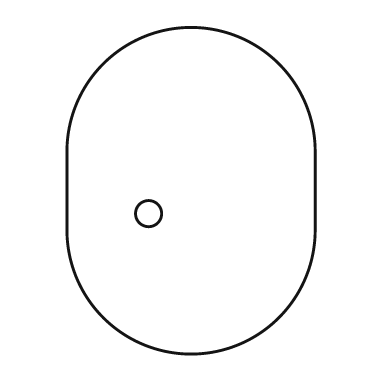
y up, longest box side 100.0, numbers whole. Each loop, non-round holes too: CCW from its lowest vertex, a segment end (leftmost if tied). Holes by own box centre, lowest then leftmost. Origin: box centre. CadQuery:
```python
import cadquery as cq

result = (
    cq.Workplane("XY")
    .moveTo(-38.0, -12.0)
    .threePointArc((0.0, -50.0), (38.0, -12.0))
    .lineTo(38.0, 12.0)
    .threePointArc((0.0, 50.0), (-38.0, 12.0))
    .close()
    .moveTo(-13.0, -7.0)
    .circle(4.0)
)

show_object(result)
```